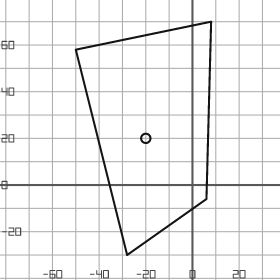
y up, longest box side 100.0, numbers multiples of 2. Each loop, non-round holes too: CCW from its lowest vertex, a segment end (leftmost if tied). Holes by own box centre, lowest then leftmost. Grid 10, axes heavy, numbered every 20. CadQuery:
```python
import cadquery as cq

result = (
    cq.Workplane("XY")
    .moveTo(-28.0, -30.0)
    .lineTo(6.0, -6.0)
    .lineTo(8.0, 70.0)
    .lineTo(-50.0, 58.0)
    .close()
    .moveTo(-20.0, 20.0)
    .circle(2.0)
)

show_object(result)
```